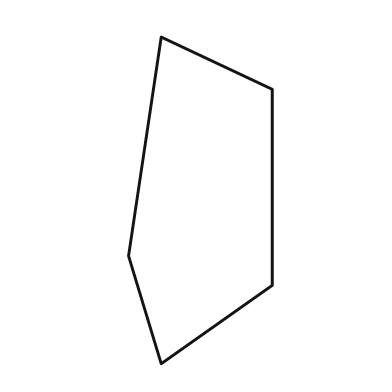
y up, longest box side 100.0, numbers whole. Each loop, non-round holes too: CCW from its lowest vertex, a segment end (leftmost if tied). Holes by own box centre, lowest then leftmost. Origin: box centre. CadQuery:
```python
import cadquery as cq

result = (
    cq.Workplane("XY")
    .moveTo(-12.0, -50.0)
    .lineTo(22.0, -26.0)
    .lineTo(22.0, 34.0)
    .lineTo(-12.0, 50.0)
    .lineTo(-22.0, -17.0)
    .close()
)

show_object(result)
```